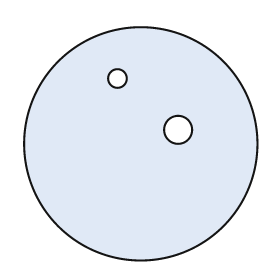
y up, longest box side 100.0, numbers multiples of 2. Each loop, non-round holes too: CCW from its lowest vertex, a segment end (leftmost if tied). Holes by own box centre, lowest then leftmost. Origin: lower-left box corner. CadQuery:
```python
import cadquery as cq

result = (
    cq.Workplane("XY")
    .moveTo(50.0, 50.0)
    .circle(50.0)
    .moveTo(66.0, 56.0)
    .circle(6.0)
    .moveTo(40.0, 78.0)
    .circle(4.0)
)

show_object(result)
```